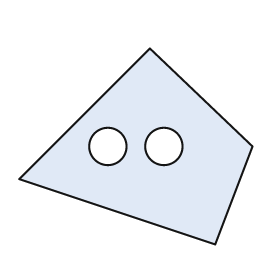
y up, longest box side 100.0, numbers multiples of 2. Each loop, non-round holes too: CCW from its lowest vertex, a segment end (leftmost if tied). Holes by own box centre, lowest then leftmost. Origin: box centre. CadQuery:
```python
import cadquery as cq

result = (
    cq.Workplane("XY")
    .moveTo(34.0, -42.0)
    .lineTo(50.0, 0.0)
    .lineTo(6.0, 42.0)
    .lineTo(-50.0, -14.0)
    .close()
    .moveTo(-12.0, 0.0)
    .circle(8.0)
    .moveTo(12.0, 0.0)
    .circle(8.0)
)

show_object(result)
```